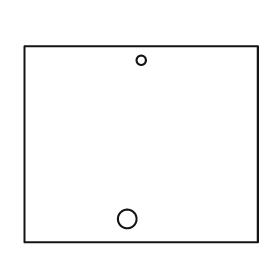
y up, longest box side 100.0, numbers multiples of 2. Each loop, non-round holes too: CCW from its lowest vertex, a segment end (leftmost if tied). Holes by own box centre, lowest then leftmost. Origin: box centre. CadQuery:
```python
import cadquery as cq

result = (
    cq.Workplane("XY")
    .moveTo(-50.0, -42.0)
    .lineTo(50.0, -42.0)
    .lineTo(50.0, 42.0)
    .lineTo(-50.0, 42.0)
    .close()
    .moveTo(-6.0, -32.0)
    .circle(4.0)
    .moveTo(0.0, 36.0)
    .circle(2.0)
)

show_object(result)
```